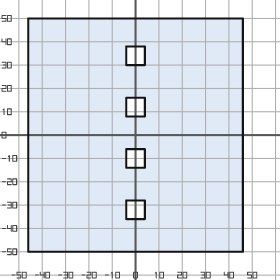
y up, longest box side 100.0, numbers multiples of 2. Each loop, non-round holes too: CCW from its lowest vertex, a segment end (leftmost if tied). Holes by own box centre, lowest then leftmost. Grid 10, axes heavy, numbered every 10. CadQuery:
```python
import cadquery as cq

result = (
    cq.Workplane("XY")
    .moveTo(-46.0, -50.0)
    .lineTo(46.0, -50.0)
    .lineTo(46.0, 50.0)
    .lineTo(-46.0, 50.0)
    .close()
    .moveTo(-4.0, -36.0)
    .lineTo(4.0, -36.0)
    .lineTo(4.0, -28.0)
    .lineTo(-4.0, -28.0)
    .close()
    .moveTo(-4.0, -14.0)
    .lineTo(4.0, -14.0)
    .lineTo(4.0, -6.0)
    .lineTo(-4.0, -6.0)
    .close()
    .moveTo(-4.0, 8.0)
    .lineTo(4.0, 8.0)
    .lineTo(4.0, 16.0)
    .lineTo(-4.0, 16.0)
    .close()
    .moveTo(-4.0, 30.0)
    .lineTo(4.0, 30.0)
    .lineTo(4.0, 38.0)
    .lineTo(-4.0, 38.0)
    .close()
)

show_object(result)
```